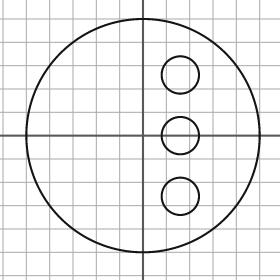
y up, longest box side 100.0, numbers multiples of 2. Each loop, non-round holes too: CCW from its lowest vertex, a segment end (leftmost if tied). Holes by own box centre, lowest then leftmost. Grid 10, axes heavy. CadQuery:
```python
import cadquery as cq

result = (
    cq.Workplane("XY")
    .moveTo(0.0, 0.0)
    .circle(50.0)
    .moveTo(16.0, -26.0)
    .circle(8.0)
    .moveTo(16.0, 0.0)
    .circle(8.0)
    .moveTo(16.0, 26.0)
    .circle(8.0)
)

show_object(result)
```